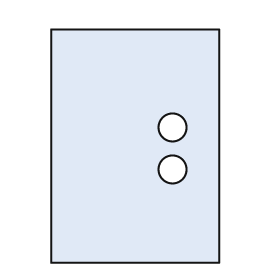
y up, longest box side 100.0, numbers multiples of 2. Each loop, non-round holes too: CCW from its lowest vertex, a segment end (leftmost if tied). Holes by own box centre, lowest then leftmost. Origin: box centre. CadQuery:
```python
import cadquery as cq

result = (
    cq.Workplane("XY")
    .moveTo(-36.0, -50.0)
    .lineTo(36.0, -50.0)
    .lineTo(36.0, 50.0)
    .lineTo(-36.0, 50.0)
    .close()
    .moveTo(16.0, -10.0)
    .circle(6.0)
    .moveTo(16.0, 8.0)
    .circle(6.0)
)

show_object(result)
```